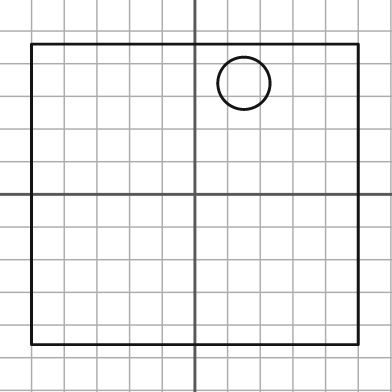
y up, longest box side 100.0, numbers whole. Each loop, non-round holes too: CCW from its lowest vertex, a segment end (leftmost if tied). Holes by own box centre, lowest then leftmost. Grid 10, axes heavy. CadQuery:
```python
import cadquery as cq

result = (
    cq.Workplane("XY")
    .moveTo(-50.0, -46.0)
    .lineTo(50.0, -46.0)
    .lineTo(50.0, 46.0)
    .lineTo(-50.0, 46.0)
    .close()
    .moveTo(15.0, 34.0)
    .circle(8.0)
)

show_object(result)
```